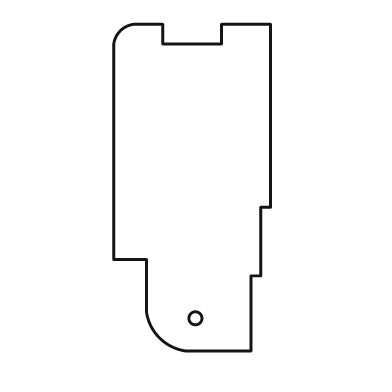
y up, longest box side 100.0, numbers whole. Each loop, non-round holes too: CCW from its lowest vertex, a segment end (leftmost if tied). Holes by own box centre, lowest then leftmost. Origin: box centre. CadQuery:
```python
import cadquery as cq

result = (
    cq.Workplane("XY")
    .moveTo(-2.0, -50.0)
    .lineTo(18.0, -50.0)
    .lineTo(18.0, -27.0)
    .lineTo(21.0, -27.0)
    .lineTo(21.0, -6.0)
    .lineTo(24.0, -6.0)
    .lineTo(24.0, 50.0)
    .lineTo(9.0, 50.0)
    .lineTo(9.0, 44.0)
    .lineTo(-9.0, 44.0)
    .lineTo(-9.0, 50.0)
    .lineTo(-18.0, 50.0)
    .threePointArc((-22.0, 48.0), (-24.0, 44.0))
    .lineTo(-24.0, -22.0)
    .lineTo(-14.0, -22.0)
    .lineTo(-14.0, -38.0)
    .threePointArc((-10.0, -46.0), (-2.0, -50.0))
    .close()
    .moveTo(1.0, -40.0)
    .circle(2.0)
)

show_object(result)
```